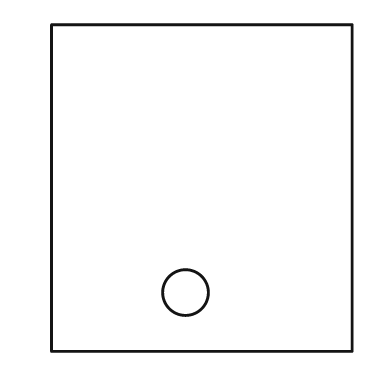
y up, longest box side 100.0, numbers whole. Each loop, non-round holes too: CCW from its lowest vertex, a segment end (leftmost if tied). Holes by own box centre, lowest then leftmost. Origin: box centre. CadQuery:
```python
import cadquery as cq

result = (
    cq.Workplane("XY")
    .moveTo(-46.0, -50.0)
    .lineTo(46.0, -50.0)
    .lineTo(46.0, 50.0)
    .lineTo(-46.0, 50.0)
    .close()
    .moveTo(-5.0, -32.0)
    .circle(7.0)
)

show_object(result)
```